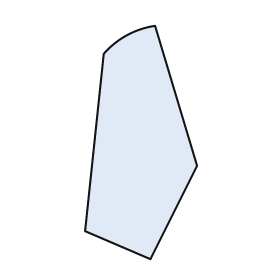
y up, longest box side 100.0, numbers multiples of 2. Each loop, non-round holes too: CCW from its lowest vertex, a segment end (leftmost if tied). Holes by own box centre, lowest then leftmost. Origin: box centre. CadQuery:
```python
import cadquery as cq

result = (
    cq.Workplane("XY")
    .moveTo(4.0, -50.0)
    .lineTo(24.0, -10.0)
    .lineTo(6.0, 50.0)
    .threePointArc((-6.0, 46.0), (-16.0, 38.0))
    .lineTo(-24.0, -38.0)
    .close()
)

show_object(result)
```